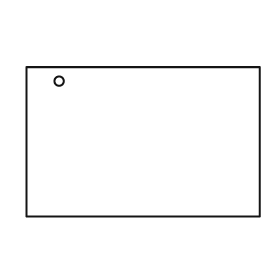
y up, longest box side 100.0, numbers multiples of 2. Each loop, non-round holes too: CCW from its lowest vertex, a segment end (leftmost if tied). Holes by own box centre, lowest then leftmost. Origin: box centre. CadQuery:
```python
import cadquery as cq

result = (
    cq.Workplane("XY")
    .moveTo(-50.0, -32.0)
    .lineTo(50.0, -32.0)
    .lineTo(50.0, 32.0)
    .lineTo(-50.0, 32.0)
    .close()
    .moveTo(-36.0, 26.0)
    .circle(2.0)
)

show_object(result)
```